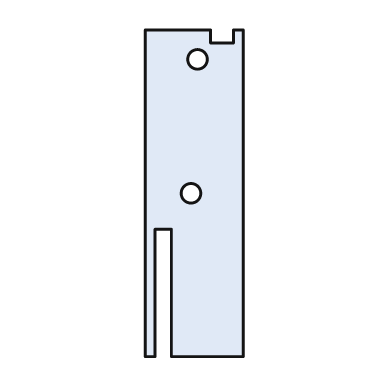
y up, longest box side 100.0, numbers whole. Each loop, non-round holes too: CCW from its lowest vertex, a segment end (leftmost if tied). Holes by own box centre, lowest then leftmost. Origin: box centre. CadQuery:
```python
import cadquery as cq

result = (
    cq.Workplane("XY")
    .moveTo(-15.0, -50.0)
    .lineTo(-12.0, -50.0)
    .lineTo(-12.0, -11.0)
    .lineTo(-7.0, -11.0)
    .lineTo(-7.0, -50.0)
    .lineTo(15.0, -50.0)
    .lineTo(15.0, 50.0)
    .lineTo(12.0, 50.0)
    .lineTo(12.0, 46.0)
    .lineTo(5.0, 46.0)
    .lineTo(5.0, 50.0)
    .lineTo(-15.0, 50.0)
    .close()
    .moveTo(-1.0, 0.0)
    .circle(3.0)
    .moveTo(1.0, 41.0)
    .circle(3.0)
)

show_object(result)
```